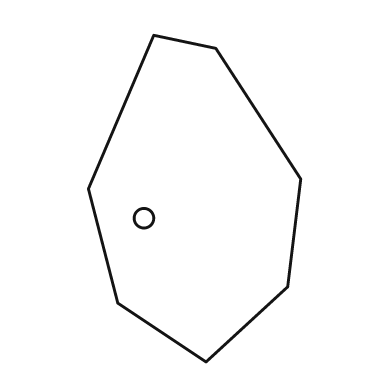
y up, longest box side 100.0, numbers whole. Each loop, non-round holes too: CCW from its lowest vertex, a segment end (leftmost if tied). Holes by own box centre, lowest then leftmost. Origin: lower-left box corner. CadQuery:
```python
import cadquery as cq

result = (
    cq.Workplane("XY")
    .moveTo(36.0, 0.0)
    .lineTo(61.0, 23.0)
    .lineTo(65.0, 56.0)
    .lineTo(39.0, 96.0)
    .lineTo(20.0, 100.0)
    .lineTo(0.0, 53.0)
    .lineTo(9.0, 18.0)
    .close()
    .moveTo(17.0, 44.0)
    .circle(3.0)
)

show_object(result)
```